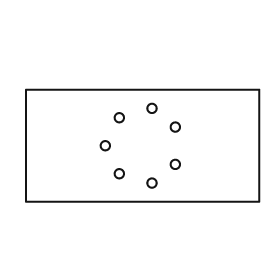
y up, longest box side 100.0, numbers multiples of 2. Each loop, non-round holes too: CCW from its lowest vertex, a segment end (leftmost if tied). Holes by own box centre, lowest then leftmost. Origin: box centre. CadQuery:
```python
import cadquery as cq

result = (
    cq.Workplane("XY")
    .moveTo(-50.0, -24.0)
    .lineTo(50.0, -24.0)
    .lineTo(50.0, 24.0)
    .lineTo(-50.0, 24.0)
    .close()
    .moveTo(4.0, -16.0)
    .circle(2.0)
    .moveTo(-10.0, -12.0)
    .circle(2.0)
    .moveTo(14.0, -8.0)
    .circle(2.0)
    .moveTo(-16.0, 0.0)
    .circle(2.0)
    .moveTo(14.0, 8.0)
    .circle(2.0)
    .moveTo(-10.0, 12.0)
    .circle(2.0)
    .moveTo(4.0, 16.0)
    .circle(2.0)
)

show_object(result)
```